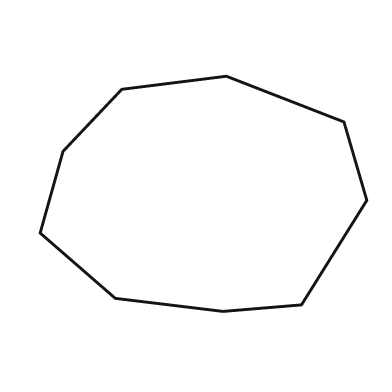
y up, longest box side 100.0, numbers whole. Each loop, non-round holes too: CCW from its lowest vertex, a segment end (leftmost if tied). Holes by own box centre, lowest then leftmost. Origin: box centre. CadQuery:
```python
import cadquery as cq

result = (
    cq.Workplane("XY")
    .moveTo(6.0, -36.0)
    .lineTo(30.0, -34.0)
    .lineTo(50.0, -2.0)
    .lineTo(43.0, 22.0)
    .lineTo(7.0, 36.0)
    .lineTo(-25.0, 32.0)
    .lineTo(-43.0, 13.0)
    .lineTo(-50.0, -12.0)
    .lineTo(-27.0, -32.0)
    .close()
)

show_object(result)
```